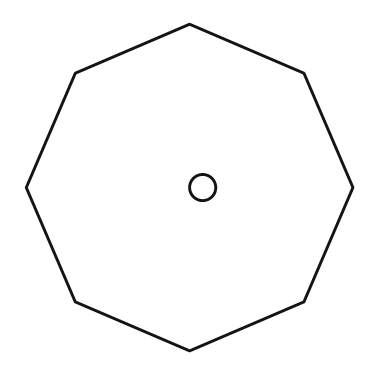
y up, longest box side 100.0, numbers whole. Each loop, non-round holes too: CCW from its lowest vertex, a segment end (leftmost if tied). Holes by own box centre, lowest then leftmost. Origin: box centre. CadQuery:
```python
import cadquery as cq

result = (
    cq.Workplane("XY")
    .moveTo(0.0, -50.0)
    .lineTo(35.0, -35.0)
    .lineTo(50.0, 0.0)
    .lineTo(35.0, 35.0)
    .lineTo(0.0, 50.0)
    .lineTo(-35.0, 35.0)
    .lineTo(-50.0, 0.0)
    .lineTo(-35.0, -35.0)
    .close()
    .moveTo(4.0, 0.0)
    .circle(4.0)
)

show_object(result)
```